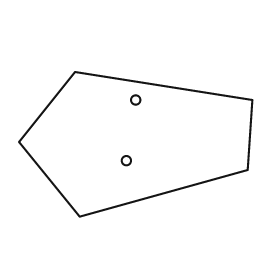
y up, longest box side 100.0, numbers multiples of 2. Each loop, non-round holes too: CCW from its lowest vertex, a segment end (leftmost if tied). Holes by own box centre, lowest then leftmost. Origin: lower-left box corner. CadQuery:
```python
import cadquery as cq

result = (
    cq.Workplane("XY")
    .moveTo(26.0, 0.0)
    .lineTo(98.0, 20.0)
    .lineTo(100.0, 50.0)
    .lineTo(24.0, 62.0)
    .lineTo(0.0, 32.0)
    .close()
    .moveTo(46.0, 24.0)
    .circle(2.0)
    .moveTo(50.0, 50.0)
    .circle(2.0)
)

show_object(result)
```